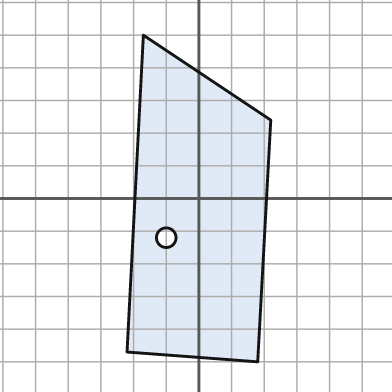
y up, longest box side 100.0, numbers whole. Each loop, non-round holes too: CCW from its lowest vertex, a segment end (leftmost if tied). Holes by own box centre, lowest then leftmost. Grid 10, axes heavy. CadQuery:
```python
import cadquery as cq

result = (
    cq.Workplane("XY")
    .moveTo(18.0, -50.0)
    .lineTo(22.0, 24.0)
    .lineTo(-17.0, 50.0)
    .lineTo(-22.0, -47.0)
    .close()
    .moveTo(-10.0, -12.0)
    .circle(3.0)
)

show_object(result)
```